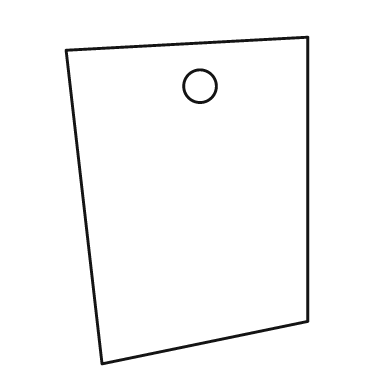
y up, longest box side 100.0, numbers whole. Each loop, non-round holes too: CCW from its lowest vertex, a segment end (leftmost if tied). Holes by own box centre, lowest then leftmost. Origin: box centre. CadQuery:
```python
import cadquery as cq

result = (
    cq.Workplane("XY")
    .moveTo(-26.0, -50.0)
    .lineTo(37.0, -37.0)
    .lineTo(37.0, 50.0)
    .lineTo(-37.0, 46.0)
    .close()
    .moveTo(4.0, 35.0)
    .circle(5.0)
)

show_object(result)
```